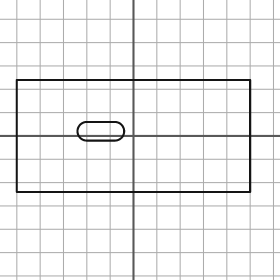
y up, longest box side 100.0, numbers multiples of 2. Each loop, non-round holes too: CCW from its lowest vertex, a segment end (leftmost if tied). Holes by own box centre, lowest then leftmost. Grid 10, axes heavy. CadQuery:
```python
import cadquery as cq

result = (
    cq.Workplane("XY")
    .moveTo(-50.0, -24.0)
    .lineTo(50.0, -24.0)
    .lineTo(50.0, 24.0)
    .lineTo(-50.0, 24.0)
    .close()
    .moveTo(-20.0, -2.0)
    .lineTo(-8.0, -2.0)
    .threePointArc((-4.0, 2.0), (-8.0, 6.0))
    .lineTo(-20.0, 6.0)
    .threePointArc((-24.0, 2.0), (-20.0, -2.0))
    .close()
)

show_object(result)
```